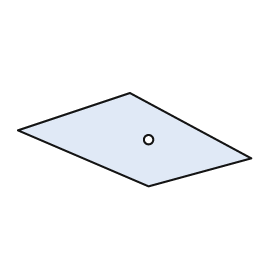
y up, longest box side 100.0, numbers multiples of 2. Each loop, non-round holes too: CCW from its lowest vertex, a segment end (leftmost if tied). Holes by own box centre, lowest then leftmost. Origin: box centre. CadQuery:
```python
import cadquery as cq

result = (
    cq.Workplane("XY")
    .moveTo(6.0, -20.0)
    .lineTo(50.0, -8.0)
    .lineTo(-2.0, 20.0)
    .lineTo(-50.0, 4.0)
    .close()
    .moveTo(6.0, 0.0)
    .circle(2.0)
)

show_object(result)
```